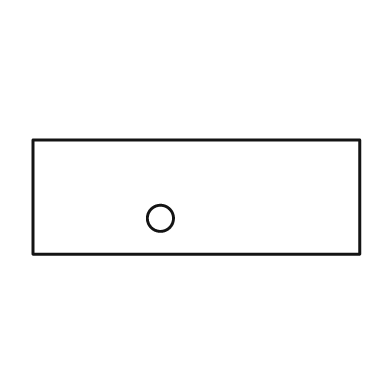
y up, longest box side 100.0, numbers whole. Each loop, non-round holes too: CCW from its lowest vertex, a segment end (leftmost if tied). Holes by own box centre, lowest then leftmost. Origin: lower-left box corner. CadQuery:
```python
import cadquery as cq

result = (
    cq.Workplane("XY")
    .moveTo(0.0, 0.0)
    .lineTo(100.0, 0.0)
    .lineTo(100.0, 35.0)
    .lineTo(0.0, 35.0)
    .close()
    .moveTo(39.0, 11.0)
    .circle(4.0)
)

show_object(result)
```